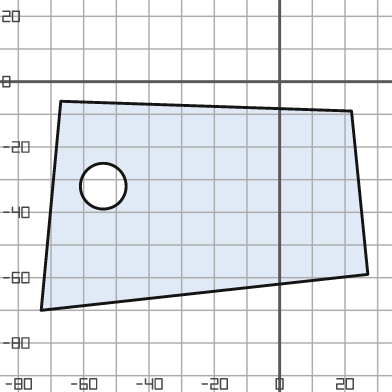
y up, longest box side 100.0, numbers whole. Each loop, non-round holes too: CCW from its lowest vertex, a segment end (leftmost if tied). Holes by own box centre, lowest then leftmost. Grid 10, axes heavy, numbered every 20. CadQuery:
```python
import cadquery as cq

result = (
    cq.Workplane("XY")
    .moveTo(-73.0, -70.0)
    .lineTo(27.0, -59.0)
    .lineTo(22.0, -9.0)
    .lineTo(-67.0, -6.0)
    .close()
    .moveTo(-54.0, -32.0)
    .circle(7.0)
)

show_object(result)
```